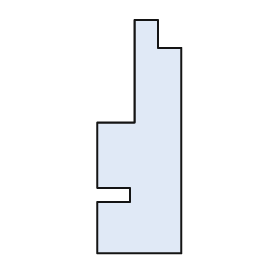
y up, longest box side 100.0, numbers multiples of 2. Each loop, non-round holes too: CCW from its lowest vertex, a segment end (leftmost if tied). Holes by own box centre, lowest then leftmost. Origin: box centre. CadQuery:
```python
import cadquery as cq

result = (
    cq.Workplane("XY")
    .moveTo(-18.0, -50.0)
    .lineTo(18.0, -50.0)
    .lineTo(18.0, 38.0)
    .lineTo(8.0, 38.0)
    .lineTo(8.0, 50.0)
    .lineTo(-2.0, 50.0)
    .lineTo(-2.0, 6.0)
    .lineTo(-18.0, 6.0)
    .lineTo(-18.0, -22.0)
    .lineTo(-4.0, -22.0)
    .lineTo(-4.0, -28.0)
    .lineTo(-18.0, -28.0)
    .close()
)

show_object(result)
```